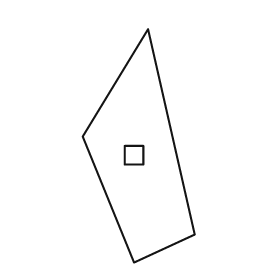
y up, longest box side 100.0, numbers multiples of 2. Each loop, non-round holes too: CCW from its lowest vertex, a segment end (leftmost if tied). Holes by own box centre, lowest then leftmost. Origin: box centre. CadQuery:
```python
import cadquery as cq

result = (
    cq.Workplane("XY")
    .moveTo(-2.0, -50.0)
    .lineTo(24.0, -38.0)
    .lineTo(4.0, 50.0)
    .lineTo(-24.0, 4.0)
    .close()
    .moveTo(-6.0, -8.0)
    .lineTo(2.0, -8.0)
    .lineTo(2.0, 0.0)
    .lineTo(-6.0, 0.0)
    .close()
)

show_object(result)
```